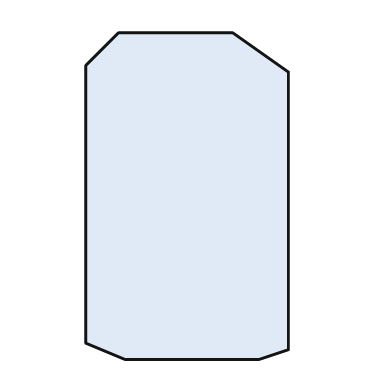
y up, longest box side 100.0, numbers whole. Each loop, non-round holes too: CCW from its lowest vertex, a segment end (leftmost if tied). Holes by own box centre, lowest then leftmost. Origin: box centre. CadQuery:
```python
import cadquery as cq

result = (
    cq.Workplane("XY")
    .moveTo(-19.0, -50.0)
    .lineTo(22.0, -50.0)
    .lineTo(31.0, -47.0)
    .lineTo(31.0, 38.0)
    .lineTo(14.0, 50.0)
    .lineTo(-21.0, 50.0)
    .lineTo(-31.0, 40.0)
    .lineTo(-31.0, -45.0)
    .close()
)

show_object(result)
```